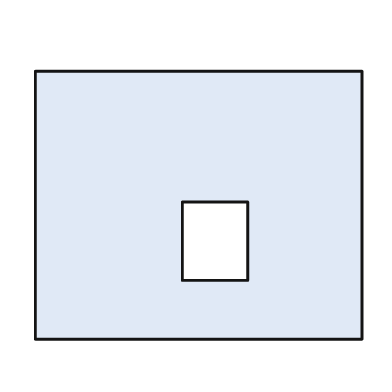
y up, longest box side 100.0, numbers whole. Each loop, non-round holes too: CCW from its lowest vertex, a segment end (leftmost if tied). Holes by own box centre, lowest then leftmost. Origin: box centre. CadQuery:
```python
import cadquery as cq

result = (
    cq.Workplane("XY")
    .moveTo(-50.0, -41.0)
    .lineTo(50.0, -41.0)
    .lineTo(50.0, 41.0)
    .lineTo(-50.0, 41.0)
    .close()
    .moveTo(-5.0, -23.0)
    .lineTo(15.0, -23.0)
    .lineTo(15.0, 1.0)
    .lineTo(-5.0, 1.0)
    .close()
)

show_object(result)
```